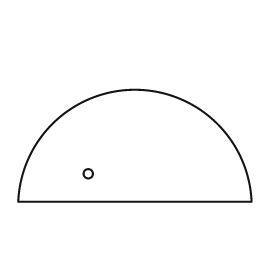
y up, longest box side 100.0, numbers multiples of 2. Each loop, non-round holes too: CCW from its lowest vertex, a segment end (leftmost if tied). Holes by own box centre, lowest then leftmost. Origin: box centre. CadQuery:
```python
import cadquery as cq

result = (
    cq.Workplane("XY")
    .moveTo(-50.0, -24.0)
    .lineTo(50.0, -24.0)
    .threePointArc((0.0, 24.0), (-50.0, -24.0))
    .close()
    .moveTo(-20.0, -12.0)
    .circle(2.0)
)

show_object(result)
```